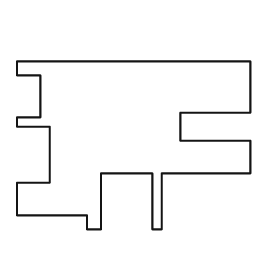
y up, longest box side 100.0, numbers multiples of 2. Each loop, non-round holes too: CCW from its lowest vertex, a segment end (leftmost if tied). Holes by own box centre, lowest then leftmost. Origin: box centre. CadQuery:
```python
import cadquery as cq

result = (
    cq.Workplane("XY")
    .moveTo(-20.0, -36.0)
    .lineTo(-14.0, -36.0)
    .lineTo(-14.0, -12.0)
    .lineTo(8.0, -12.0)
    .lineTo(8.0, -36.0)
    .lineTo(12.0, -36.0)
    .lineTo(12.0, -12.0)
    .lineTo(50.0, -12.0)
    .lineTo(50.0, 2.0)
    .lineTo(20.0, 2.0)
    .lineTo(20.0, 14.0)
    .lineTo(50.0, 14.0)
    .lineTo(50.0, 36.0)
    .lineTo(-50.0, 36.0)
    .lineTo(-50.0, 30.0)
    .lineTo(-40.0, 30.0)
    .lineTo(-40.0, 12.0)
    .lineTo(-50.0, 12.0)
    .lineTo(-50.0, 8.0)
    .lineTo(-36.0, 8.0)
    .lineTo(-36.0, -16.0)
    .lineTo(-50.0, -16.0)
    .lineTo(-50.0, -30.0)
    .lineTo(-20.0, -30.0)
    .close()
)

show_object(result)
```